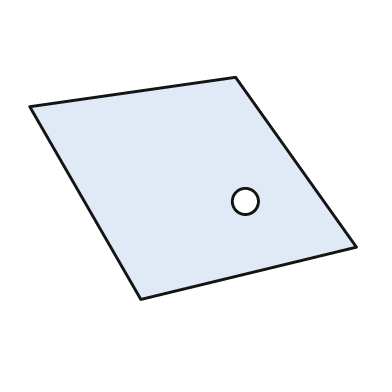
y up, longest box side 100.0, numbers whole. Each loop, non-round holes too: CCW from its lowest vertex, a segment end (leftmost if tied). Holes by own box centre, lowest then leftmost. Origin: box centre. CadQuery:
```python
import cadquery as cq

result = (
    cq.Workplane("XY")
    .moveTo(-16.0, -34.0)
    .lineTo(50.0, -18.0)
    .lineTo(13.0, 34.0)
    .lineTo(-50.0, 25.0)
    .close()
    .moveTo(16.0, -4.0)
    .circle(4.0)
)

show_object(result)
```